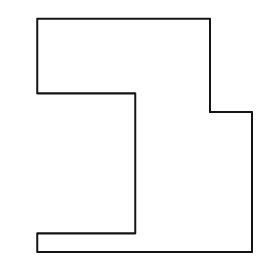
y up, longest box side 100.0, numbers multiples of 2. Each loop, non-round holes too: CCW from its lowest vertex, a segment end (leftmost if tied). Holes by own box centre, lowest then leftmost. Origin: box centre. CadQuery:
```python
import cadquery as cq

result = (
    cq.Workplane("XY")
    .moveTo(-46.0, -50.0)
    .lineTo(46.0, -50.0)
    .lineTo(46.0, 10.0)
    .lineTo(28.0, 10.0)
    .lineTo(28.0, 50.0)
    .lineTo(-46.0, 50.0)
    .lineTo(-46.0, 18.0)
    .lineTo(-4.0, 18.0)
    .lineTo(-4.0, -42.0)
    .lineTo(-46.0, -42.0)
    .close()
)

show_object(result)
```